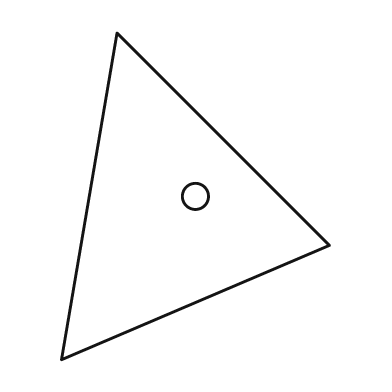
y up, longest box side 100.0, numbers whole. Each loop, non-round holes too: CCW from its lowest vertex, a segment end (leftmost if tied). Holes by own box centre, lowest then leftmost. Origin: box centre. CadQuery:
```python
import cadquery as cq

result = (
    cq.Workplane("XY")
    .moveTo(-41.0, -50.0)
    .lineTo(41.0, -15.0)
    .lineTo(-24.0, 50.0)
    .close()
    .moveTo(0.0, 0.0)
    .circle(4.0)
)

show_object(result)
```